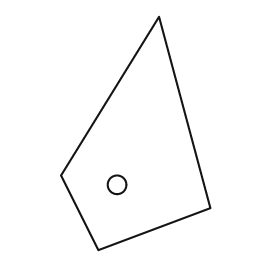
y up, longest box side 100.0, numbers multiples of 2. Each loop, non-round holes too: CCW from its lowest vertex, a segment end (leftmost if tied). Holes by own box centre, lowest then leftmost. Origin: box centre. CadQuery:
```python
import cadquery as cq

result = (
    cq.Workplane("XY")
    .moveTo(-16.0, -50.0)
    .lineTo(32.0, -32.0)
    .lineTo(10.0, 50.0)
    .lineTo(-32.0, -18.0)
    .close()
    .moveTo(-8.0, -22.0)
    .circle(4.0)
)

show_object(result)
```